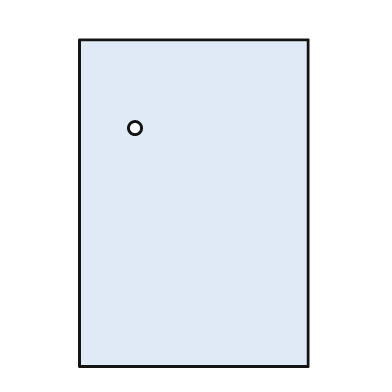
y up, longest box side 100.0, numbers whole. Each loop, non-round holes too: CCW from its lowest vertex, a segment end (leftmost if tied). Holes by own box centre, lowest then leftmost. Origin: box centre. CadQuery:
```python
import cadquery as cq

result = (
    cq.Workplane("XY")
    .moveTo(-35.0, -50.0)
    .lineTo(35.0, -50.0)
    .lineTo(35.0, 50.0)
    .lineTo(-35.0, 50.0)
    .close()
    .moveTo(-18.0, 23.0)
    .circle(2.0)
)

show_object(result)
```